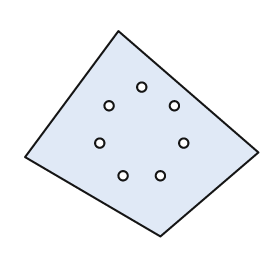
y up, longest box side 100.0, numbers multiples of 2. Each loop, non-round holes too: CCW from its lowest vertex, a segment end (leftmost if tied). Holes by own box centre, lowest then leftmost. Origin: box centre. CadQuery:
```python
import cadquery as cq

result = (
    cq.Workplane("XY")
    .moveTo(8.0, -44.0)
    .lineTo(50.0, -8.0)
    .lineTo(-10.0, 44.0)
    .lineTo(-50.0, -10.0)
    .close()
    .moveTo(-8.0, -18.0)
    .circle(2.0)
    .moveTo(8.0, -18.0)
    .circle(2.0)
    .moveTo(-18.0, -4.0)
    .circle(2.0)
    .moveTo(18.0, -4.0)
    .circle(2.0)
    .moveTo(-14.0, 12.0)
    .circle(2.0)
    .moveTo(14.0, 12.0)
    .circle(2.0)
    .moveTo(0.0, 20.0)
    .circle(2.0)
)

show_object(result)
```